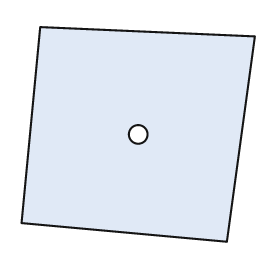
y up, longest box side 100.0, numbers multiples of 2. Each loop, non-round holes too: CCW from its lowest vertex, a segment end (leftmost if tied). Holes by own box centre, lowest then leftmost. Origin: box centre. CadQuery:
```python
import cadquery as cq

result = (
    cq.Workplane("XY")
    .moveTo(38.0, -46.0)
    .lineTo(50.0, 42.0)
    .lineTo(-42.0, 46.0)
    .lineTo(-50.0, -38.0)
    .close()
    .moveTo(0.0, 0.0)
    .circle(4.0)
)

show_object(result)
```